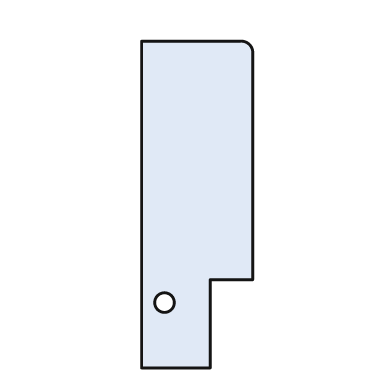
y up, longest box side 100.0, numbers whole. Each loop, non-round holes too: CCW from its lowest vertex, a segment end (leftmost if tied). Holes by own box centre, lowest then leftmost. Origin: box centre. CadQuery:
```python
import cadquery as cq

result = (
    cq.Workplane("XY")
    .moveTo(-17.0, -50.0)
    .lineTo(4.0, -50.0)
    .lineTo(4.0, -23.0)
    .lineTo(17.0, -23.0)
    .lineTo(17.0, 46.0)
    .threePointArc((16.0, 49.0), (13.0, 50.0))
    .lineTo(-17.0, 50.0)
    .close()
    .moveTo(-10.0, -30.0)
    .circle(3.0)
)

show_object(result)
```